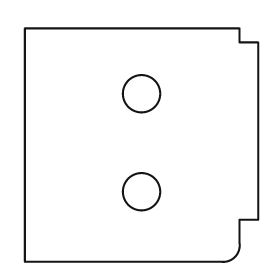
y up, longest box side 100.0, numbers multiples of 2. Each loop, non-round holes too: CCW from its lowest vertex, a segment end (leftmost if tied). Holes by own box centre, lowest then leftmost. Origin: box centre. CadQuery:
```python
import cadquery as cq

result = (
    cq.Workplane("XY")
    .moveTo(-50.0, -50.0)
    .lineTo(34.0, -50.0)
    .threePointArc((40.0, -48.0), (42.0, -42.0))
    .lineTo(42.0, -32.0)
    .lineTo(50.0, -32.0)
    .lineTo(50.0, 44.0)
    .lineTo(42.0, 44.0)
    .lineTo(42.0, 50.0)
    .lineTo(-50.0, 50.0)
    .close()
    .moveTo(0.0, -20.0)
    .circle(8.0)
    .moveTo(0.0, 22.0)
    .circle(8.0)
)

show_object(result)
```